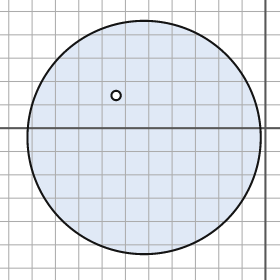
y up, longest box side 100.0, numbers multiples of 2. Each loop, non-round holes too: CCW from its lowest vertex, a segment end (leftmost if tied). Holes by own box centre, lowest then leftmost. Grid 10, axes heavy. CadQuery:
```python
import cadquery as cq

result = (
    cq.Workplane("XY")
    .moveTo(-52.0, -4.0)
    .circle(50.0)
    .moveTo(-64.0, 14.0)
    .circle(2.0)
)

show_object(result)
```